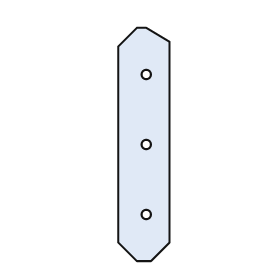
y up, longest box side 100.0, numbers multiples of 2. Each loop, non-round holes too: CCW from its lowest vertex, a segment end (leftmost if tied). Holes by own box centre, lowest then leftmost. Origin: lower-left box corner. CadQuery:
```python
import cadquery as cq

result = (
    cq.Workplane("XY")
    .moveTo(8.0, 0.0)
    .lineTo(14.0, 0.0)
    .lineTo(22.0, 8.0)
    .lineTo(22.0, 94.0)
    .lineTo(12.0, 100.0)
    .lineTo(8.0, 100.0)
    .lineTo(0.0, 92.0)
    .lineTo(0.0, 8.0)
    .close()
    .moveTo(12.0, 20.0)
    .circle(2.0)
    .moveTo(12.0, 50.0)
    .circle(2.0)
    .moveTo(12.0, 80.0)
    .circle(2.0)
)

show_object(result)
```